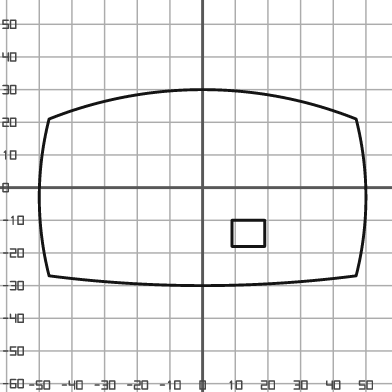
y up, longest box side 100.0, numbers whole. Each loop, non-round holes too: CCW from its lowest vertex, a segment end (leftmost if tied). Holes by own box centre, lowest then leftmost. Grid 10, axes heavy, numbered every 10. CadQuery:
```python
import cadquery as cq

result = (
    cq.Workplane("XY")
    .moveTo(-47.0, -27.0)
    .threePointArc((0.0, -30.0), (47.0, -27.0))
    .threePointArc((50.0, -3.0), (47.0, 21.0))
    .threePointArc((0.0, 30.0), (-47.0, 21.0))
    .threePointArc((-50.0, -3.0), (-47.0, -27.0))
    .close()
    .moveTo(9.0, -18.0)
    .lineTo(19.0, -18.0)
    .lineTo(19.0, -10.0)
    .lineTo(9.0, -10.0)
    .close()
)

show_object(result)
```